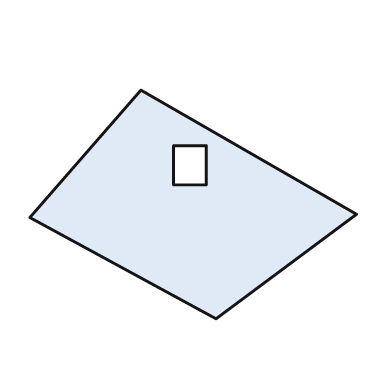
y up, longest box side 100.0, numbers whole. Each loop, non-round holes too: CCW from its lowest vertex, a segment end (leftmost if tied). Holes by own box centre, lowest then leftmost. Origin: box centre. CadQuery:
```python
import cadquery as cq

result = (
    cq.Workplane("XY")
    .moveTo(7.0, -35.0)
    .lineTo(50.0, -3.0)
    .lineTo(-16.0, 35.0)
    .lineTo(-50.0, -4.0)
    .close()
    .moveTo(-6.0, 6.0)
    .lineTo(4.0, 6.0)
    .lineTo(4.0, 18.0)
    .lineTo(-6.0, 18.0)
    .close()
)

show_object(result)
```